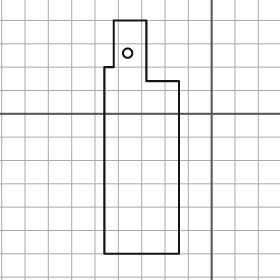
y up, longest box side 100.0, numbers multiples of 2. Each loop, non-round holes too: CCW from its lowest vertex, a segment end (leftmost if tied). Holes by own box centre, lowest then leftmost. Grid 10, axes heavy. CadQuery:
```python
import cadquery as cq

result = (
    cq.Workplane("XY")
    .moveTo(-46.0, -60.0)
    .lineTo(-14.0, -60.0)
    .lineTo(-14.0, 14.0)
    .lineTo(-28.0, 14.0)
    .lineTo(-28.0, 40.0)
    .lineTo(-42.0, 40.0)
    .lineTo(-42.0, 20.0)
    .lineTo(-46.0, 20.0)
    .close()
    .moveTo(-36.0, 26.0)
    .circle(2.0)
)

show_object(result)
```